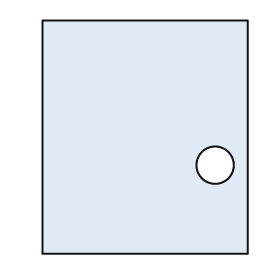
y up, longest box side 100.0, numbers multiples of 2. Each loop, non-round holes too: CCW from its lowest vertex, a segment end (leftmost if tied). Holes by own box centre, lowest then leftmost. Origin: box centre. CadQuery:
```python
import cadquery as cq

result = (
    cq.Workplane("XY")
    .moveTo(-44.0, -50.0)
    .lineTo(44.0, -50.0)
    .lineTo(44.0, 50.0)
    .lineTo(-44.0, 50.0)
    .close()
    .moveTo(30.0, -12.0)
    .circle(8.0)
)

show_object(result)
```